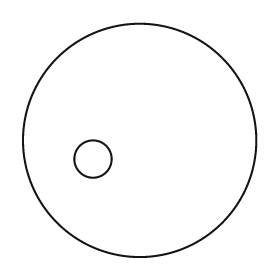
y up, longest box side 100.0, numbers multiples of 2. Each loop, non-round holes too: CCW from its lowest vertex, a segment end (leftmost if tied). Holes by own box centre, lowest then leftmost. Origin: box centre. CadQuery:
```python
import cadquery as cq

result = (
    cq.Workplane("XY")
    .moveTo(0.0, 0.0)
    .circle(50.0)
    .moveTo(-20.0, -8.0)
    .circle(8.0)
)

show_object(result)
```